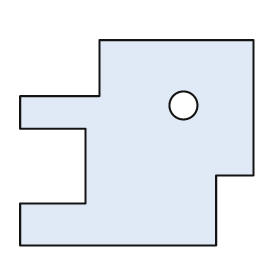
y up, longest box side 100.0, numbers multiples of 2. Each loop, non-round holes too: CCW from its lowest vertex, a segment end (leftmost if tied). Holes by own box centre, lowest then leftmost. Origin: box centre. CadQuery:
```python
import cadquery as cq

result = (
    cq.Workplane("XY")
    .moveTo(-50.0, -44.0)
    .lineTo(34.0, -44.0)
    .lineTo(34.0, -14.0)
    .lineTo(50.0, -14.0)
    .lineTo(50.0, 44.0)
    .lineTo(-16.0, 44.0)
    .lineTo(-16.0, 20.0)
    .lineTo(-50.0, 20.0)
    .lineTo(-50.0, 6.0)
    .lineTo(-22.0, 6.0)
    .lineTo(-22.0, -26.0)
    .lineTo(-50.0, -26.0)
    .close()
    .moveTo(20.0, 16.0)
    .circle(6.0)
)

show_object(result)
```